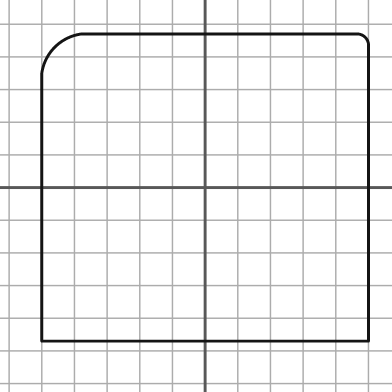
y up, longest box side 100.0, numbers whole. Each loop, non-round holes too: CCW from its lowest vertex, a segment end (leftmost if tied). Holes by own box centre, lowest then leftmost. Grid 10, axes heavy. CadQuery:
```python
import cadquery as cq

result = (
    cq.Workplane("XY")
    .moveTo(-50.0, -47.0)
    .lineTo(50.0, -47.0)
    .lineTo(50.0, 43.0)
    .threePointArc((49.0, 46.0), (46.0, 47.0))
    .lineTo(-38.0, 47.0)
    .threePointArc((-46.0, 43.0), (-50.0, 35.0))
    .close()
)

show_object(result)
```